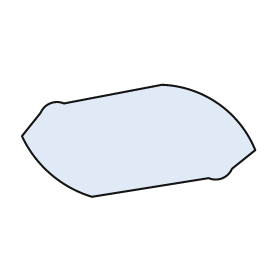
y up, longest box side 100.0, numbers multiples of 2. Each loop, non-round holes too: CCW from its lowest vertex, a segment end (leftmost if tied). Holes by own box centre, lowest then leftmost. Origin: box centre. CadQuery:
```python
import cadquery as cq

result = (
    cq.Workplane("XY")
    .moveTo(-20.0, -24.0)
    .lineTo(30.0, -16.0)
    .threePointArc((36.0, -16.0), (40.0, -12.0))
    .lineTo(50.0, -4.0)
    .threePointArc((34.0, 16.0), (10.0, 24.0))
    .lineTo(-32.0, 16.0)
    .threePointArc((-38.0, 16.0), (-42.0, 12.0))
    .lineTo(-50.0, 2.0)
    .threePointArc((-38.0, -14.0), (-20.0, -24.0))
    .close()
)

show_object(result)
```